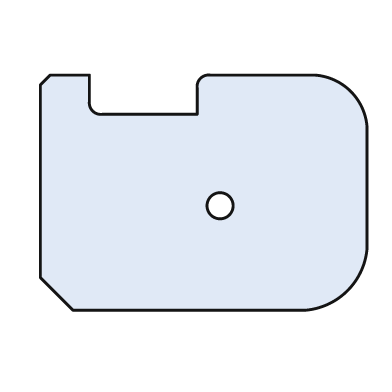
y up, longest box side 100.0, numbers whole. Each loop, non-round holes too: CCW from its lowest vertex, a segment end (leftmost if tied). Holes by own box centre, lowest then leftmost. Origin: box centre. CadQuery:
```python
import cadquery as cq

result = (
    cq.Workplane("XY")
    .moveTo(-40.0, -36.0)
    .lineTo(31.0, -36.0)
    .threePointArc((44.0, -30.0), (50.0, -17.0))
    .lineTo(50.0, 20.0)
    .threePointArc((45.0, 31.0), (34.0, 36.0))
    .lineTo(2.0, 36.0)
    .threePointArc((-1.0, 35.0), (-2.0, 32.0))
    .lineTo(-2.0, 24.0)
    .lineTo(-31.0, 24.0)
    .threePointArc((-34.0, 25.0), (-35.0, 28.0))
    .lineTo(-35.0, 36.0)
    .lineTo(-47.0, 36.0)
    .lineTo(-50.0, 33.0)
    .lineTo(-50.0, -26.0)
    .close()
    .moveTo(5.0, -4.0)
    .circle(4.0)
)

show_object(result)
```